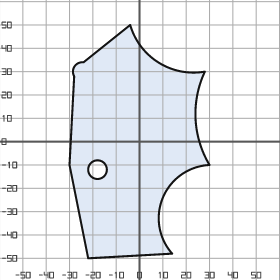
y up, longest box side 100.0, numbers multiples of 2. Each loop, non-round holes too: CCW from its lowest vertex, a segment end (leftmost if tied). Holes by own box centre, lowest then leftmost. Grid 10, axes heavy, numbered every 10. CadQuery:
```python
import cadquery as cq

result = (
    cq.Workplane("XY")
    .moveTo(-22.0, -50.0)
    .lineTo(14.0, -48.0)
    .threePointArc((10.0, -24.0), (30.0, -10.0))
    .threePointArc((24.0, 10.0), (28.0, 30.0))
    .threePointArc((8.0, 34.0), (-4.0, 50.0))
    .lineTo(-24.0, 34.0)
    .threePointArc((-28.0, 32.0), (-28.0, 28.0))
    .lineTo(-30.0, -10.0)
    .close()
    .moveTo(-18.0, -12.0)
    .circle(4.0)
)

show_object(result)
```